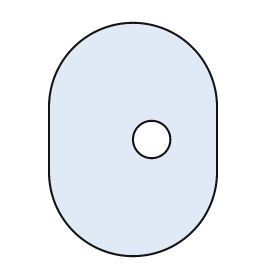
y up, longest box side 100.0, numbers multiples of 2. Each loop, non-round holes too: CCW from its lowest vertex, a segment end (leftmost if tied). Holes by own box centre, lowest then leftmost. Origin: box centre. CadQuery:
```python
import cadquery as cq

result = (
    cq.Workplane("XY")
    .moveTo(-36.0, -14.0)
    .threePointArc((0.0, -50.0), (36.0, -14.0))
    .lineTo(36.0, 14.0)
    .threePointArc((0.0, 50.0), (-36.0, 14.0))
    .close()
    .moveTo(8.0, 0.0)
    .circle(8.0)
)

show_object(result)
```